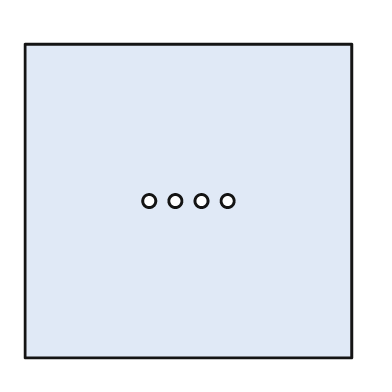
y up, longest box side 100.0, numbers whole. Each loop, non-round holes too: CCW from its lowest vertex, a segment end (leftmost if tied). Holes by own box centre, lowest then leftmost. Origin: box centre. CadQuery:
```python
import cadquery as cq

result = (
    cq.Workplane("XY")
    .moveTo(-50.0, -48.0)
    .lineTo(50.0, -48.0)
    .lineTo(50.0, 48.0)
    .lineTo(-50.0, 48.0)
    .close()
    .moveTo(-12.0, 0.0)
    .circle(2.0)
    .moveTo(-4.0, 0.0)
    .circle(2.0)
    .moveTo(4.0, 0.0)
    .circle(2.0)
    .moveTo(12.0, 0.0)
    .circle(2.0)
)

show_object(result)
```